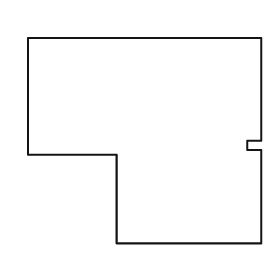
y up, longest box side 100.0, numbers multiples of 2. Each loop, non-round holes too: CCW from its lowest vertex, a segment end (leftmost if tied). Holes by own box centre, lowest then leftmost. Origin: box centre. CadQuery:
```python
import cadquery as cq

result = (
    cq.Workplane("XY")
    .moveTo(-12.0, -44.0)
    .lineTo(50.0, -44.0)
    .lineTo(50.0, -4.0)
    .lineTo(44.0, -4.0)
    .lineTo(44.0, 0.0)
    .lineTo(50.0, 0.0)
    .lineTo(50.0, 44.0)
    .lineTo(-50.0, 44.0)
    .lineTo(-50.0, -6.0)
    .lineTo(-12.0, -6.0)
    .close()
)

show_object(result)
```